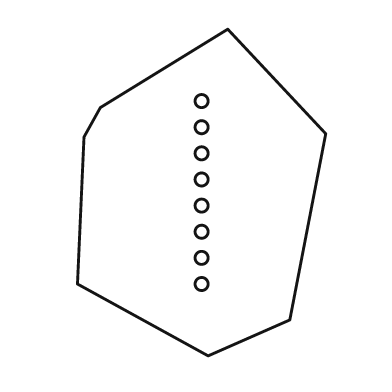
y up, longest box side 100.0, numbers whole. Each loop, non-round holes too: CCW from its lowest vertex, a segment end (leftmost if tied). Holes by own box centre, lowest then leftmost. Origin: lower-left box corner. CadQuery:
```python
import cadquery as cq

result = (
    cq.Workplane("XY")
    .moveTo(40.0, 0.0)
    .lineTo(65.0, 11.0)
    .lineTo(76.0, 68.0)
    .lineTo(46.0, 100.0)
    .lineTo(7.0, 76.0)
    .lineTo(2.0, 67.0)
    .lineTo(0.0, 22.0)
    .close()
    .moveTo(38.0, 22.0)
    .circle(2.0)
    .moveTo(38.0, 30.0)
    .circle(2.0)
    .moveTo(38.0, 38.0)
    .circle(2.0)
    .moveTo(38.0, 46.0)
    .circle(2.0)
    .moveTo(38.0, 54.0)
    .circle(2.0)
    .moveTo(38.0, 62.0)
    .circle(2.0)
    .moveTo(38.0, 70.0)
    .circle(2.0)
    .moveTo(38.0, 78.0)
    .circle(2.0)
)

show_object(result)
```